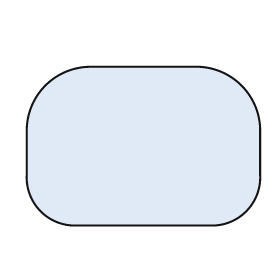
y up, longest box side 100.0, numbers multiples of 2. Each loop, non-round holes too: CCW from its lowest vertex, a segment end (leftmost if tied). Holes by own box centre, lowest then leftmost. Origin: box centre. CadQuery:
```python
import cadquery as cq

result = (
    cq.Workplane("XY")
    .moveTo(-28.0, -34.0)
    .lineTo(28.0, -34.0)
    .threePointArc((44.0, -28.0), (50.0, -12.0))
    .lineTo(50.0, 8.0)
    .threePointArc((42.0, 26.0), (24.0, 34.0))
    .lineTo(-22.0, 34.0)
    .threePointArc((-42.0, 26.0), (-50.0, 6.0))
    .lineTo(-50.0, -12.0)
    .threePointArc((-44.0, -28.0), (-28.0, -34.0))
    .close()
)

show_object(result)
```